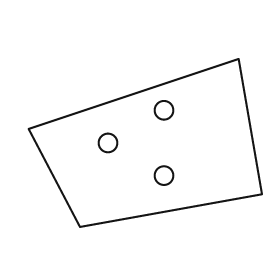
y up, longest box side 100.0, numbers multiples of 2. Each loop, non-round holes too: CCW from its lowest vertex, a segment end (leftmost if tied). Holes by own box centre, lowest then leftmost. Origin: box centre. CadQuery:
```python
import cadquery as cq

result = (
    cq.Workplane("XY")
    .moveTo(-28.0, -36.0)
    .lineTo(50.0, -22.0)
    .lineTo(40.0, 36.0)
    .lineTo(-50.0, 6.0)
    .close()
    .moveTo(8.0, -14.0)
    .circle(4.0)
    .moveTo(-16.0, 0.0)
    .circle(4.0)
    .moveTo(8.0, 14.0)
    .circle(4.0)
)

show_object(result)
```